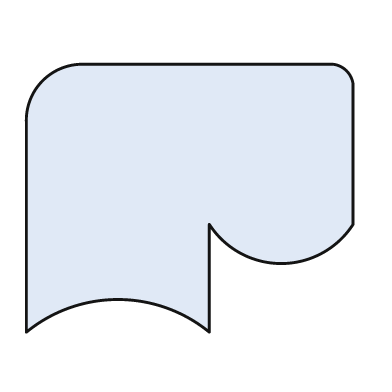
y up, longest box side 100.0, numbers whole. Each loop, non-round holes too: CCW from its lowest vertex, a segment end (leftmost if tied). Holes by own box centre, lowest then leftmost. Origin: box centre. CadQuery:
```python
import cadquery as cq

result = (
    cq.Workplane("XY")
    .moveTo(-50.0, -41.0)
    .threePointArc((-22.0, -31.0), (6.0, -41.0))
    .lineTo(6.0, -8.0)
    .threePointArc((28.0, -20.0), (50.0, -8.0))
    .lineTo(50.0, 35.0)
    .threePointArc((48.0, 39.0), (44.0, 41.0))
    .lineTo(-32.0, 41.0)
    .threePointArc((-45.0, 36.0), (-50.0, 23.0))
    .close()
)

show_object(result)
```